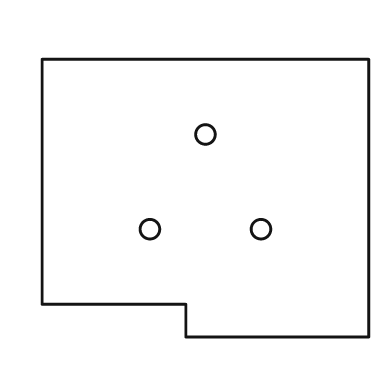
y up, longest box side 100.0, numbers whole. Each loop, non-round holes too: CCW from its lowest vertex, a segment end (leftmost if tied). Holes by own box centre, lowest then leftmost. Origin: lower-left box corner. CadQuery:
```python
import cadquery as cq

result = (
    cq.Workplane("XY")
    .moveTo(44.0, 0.0)
    .lineTo(100.0, 0.0)
    .lineTo(100.0, 85.0)
    .lineTo(0.0, 85.0)
    .lineTo(0.0, 10.0)
    .lineTo(44.0, 10.0)
    .close()
    .moveTo(33.0, 33.0)
    .circle(3.0)
    .moveTo(67.0, 33.0)
    .circle(3.0)
    .moveTo(50.0, 62.0)
    .circle(3.0)
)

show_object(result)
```